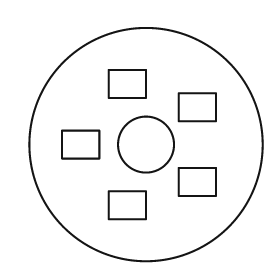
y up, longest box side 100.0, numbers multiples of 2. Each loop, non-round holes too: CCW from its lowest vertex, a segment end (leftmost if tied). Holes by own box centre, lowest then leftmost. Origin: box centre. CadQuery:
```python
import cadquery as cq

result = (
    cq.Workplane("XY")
    .moveTo(0.0, 0.0)
    .circle(50.0)
    .moveTo(-16.0, -32.0)
    .lineTo(0.0, -32.0)
    .lineTo(0.0, -20.0)
    .lineTo(-16.0, -20.0)
    .close()
    .moveTo(14.0, -22.0)
    .lineTo(30.0, -22.0)
    .lineTo(30.0, -10.0)
    .lineTo(14.0, -10.0)
    .close()
    .moveTo(-36.0, -6.0)
    .lineTo(-20.0, -6.0)
    .lineTo(-20.0, 6.0)
    .lineTo(-36.0, 6.0)
    .close()
    .moveTo(0.0, 0.0)
    .circle(12.0)
    .moveTo(14.0, 10.0)
    .lineTo(30.0, 10.0)
    .lineTo(30.0, 22.0)
    .lineTo(14.0, 22.0)
    .close()
    .moveTo(-16.0, 20.0)
    .lineTo(0.0, 20.0)
    .lineTo(0.0, 32.0)
    .lineTo(-16.0, 32.0)
    .close()
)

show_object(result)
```